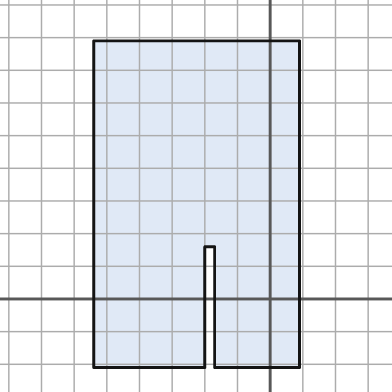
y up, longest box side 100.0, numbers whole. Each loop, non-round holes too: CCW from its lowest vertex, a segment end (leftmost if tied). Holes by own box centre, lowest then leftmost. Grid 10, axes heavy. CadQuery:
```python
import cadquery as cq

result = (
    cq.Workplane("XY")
    .moveTo(-54.0, -21.0)
    .lineTo(-20.0, -21.0)
    .lineTo(-20.0, 16.0)
    .lineTo(-17.0, 16.0)
    .lineTo(-17.0, -21.0)
    .lineTo(9.0, -21.0)
    .lineTo(9.0, 79.0)
    .lineTo(-54.0, 79.0)
    .close()
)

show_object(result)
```